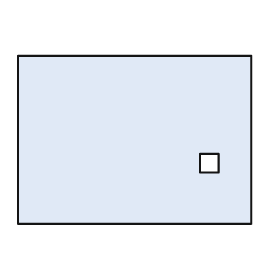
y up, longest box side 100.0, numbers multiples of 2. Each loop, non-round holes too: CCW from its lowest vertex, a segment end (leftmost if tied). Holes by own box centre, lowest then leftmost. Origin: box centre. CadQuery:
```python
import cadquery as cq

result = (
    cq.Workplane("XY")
    .moveTo(-50.0, -36.0)
    .lineTo(50.0, -36.0)
    .lineTo(50.0, 36.0)
    .lineTo(-50.0, 36.0)
    .close()
    .moveTo(28.0, -14.0)
    .lineTo(36.0, -14.0)
    .lineTo(36.0, -6.0)
    .lineTo(28.0, -6.0)
    .close()
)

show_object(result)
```